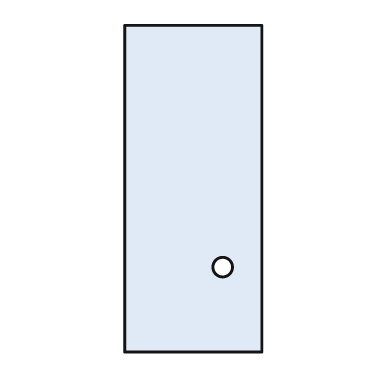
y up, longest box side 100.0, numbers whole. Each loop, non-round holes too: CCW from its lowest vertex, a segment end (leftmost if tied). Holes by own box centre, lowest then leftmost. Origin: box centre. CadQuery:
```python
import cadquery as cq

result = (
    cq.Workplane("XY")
    .moveTo(-21.0, -50.0)
    .lineTo(21.0, -50.0)
    .lineTo(21.0, 50.0)
    .lineTo(-21.0, 50.0)
    .close()
    .moveTo(9.0, -24.0)
    .circle(3.0)
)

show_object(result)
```